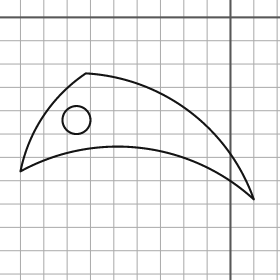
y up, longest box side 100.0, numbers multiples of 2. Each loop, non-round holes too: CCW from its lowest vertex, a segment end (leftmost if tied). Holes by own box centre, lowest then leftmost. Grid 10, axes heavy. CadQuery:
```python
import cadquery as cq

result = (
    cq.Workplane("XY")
    .moveTo(10.0, -78.0)
    .threePointArc((-18.0, -40.0), (-62.0, -24.0))
    .threePointArc((-80.0, -42.0), (-90.0, -66.0))
    .threePointArc((-38.0, -56.0), (10.0, -78.0))
    .close()
    .moveTo(-66.0, -44.0)
    .circle(6.0)
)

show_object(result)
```